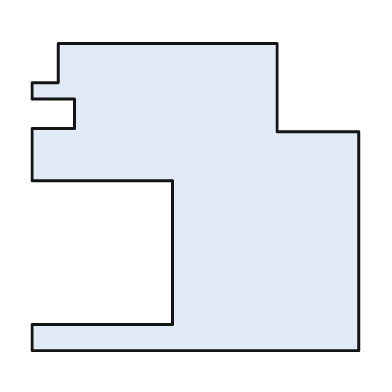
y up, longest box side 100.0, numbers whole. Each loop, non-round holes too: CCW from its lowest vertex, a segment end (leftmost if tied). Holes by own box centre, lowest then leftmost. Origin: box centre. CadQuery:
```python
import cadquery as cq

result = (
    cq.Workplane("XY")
    .moveTo(-50.0, -47.0)
    .lineTo(50.0, -47.0)
    .lineTo(50.0, 20.0)
    .lineTo(25.0, 20.0)
    .lineTo(25.0, 47.0)
    .lineTo(-42.0, 47.0)
    .lineTo(-42.0, 35.0)
    .lineTo(-50.0, 35.0)
    .lineTo(-50.0, 30.0)
    .lineTo(-37.0, 30.0)
    .lineTo(-37.0, 21.0)
    .lineTo(-50.0, 21.0)
    .lineTo(-50.0, 5.0)
    .lineTo(-7.0, 5.0)
    .lineTo(-7.0, -39.0)
    .lineTo(-50.0, -39.0)
    .close()
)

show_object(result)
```